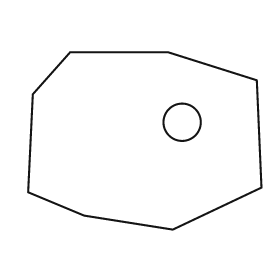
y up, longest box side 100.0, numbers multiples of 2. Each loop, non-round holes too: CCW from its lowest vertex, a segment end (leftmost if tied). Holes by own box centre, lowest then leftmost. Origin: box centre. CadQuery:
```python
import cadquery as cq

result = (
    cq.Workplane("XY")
    .moveTo(12.0, -38.0)
    .lineTo(50.0, -20.0)
    .lineTo(48.0, 26.0)
    .lineTo(10.0, 38.0)
    .lineTo(-32.0, 38.0)
    .lineTo(-48.0, 20.0)
    .lineTo(-50.0, -22.0)
    .lineTo(-26.0, -32.0)
    .close()
    .moveTo(16.0, 8.0)
    .circle(8.0)
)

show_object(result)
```